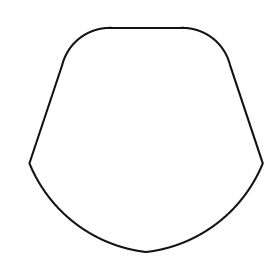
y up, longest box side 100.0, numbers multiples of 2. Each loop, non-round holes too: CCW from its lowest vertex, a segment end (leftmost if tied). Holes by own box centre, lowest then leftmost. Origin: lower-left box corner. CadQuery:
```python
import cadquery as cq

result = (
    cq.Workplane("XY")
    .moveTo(50.0, 0.0)
    .threePointArc((80.0, 12.0), (100.0, 38.0))
    .lineTo(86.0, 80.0)
    .threePointArc((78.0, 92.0), (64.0, 96.0))
    .lineTo(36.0, 96.0)
    .threePointArc((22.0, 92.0), (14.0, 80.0))
    .lineTo(0.0, 38.0)
    .threePointArc((20.0, 12.0), (50.0, 0.0))
    .close()
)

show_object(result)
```